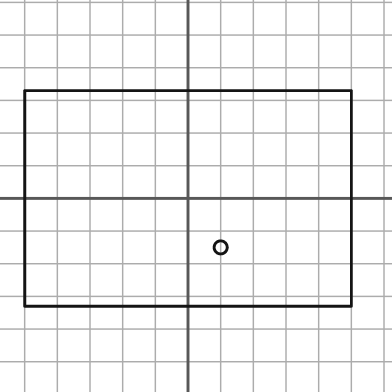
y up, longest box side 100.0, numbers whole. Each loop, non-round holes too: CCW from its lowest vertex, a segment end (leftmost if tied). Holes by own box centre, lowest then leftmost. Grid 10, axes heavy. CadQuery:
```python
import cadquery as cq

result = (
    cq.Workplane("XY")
    .moveTo(-50.0, -33.0)
    .lineTo(50.0, -33.0)
    .lineTo(50.0, 33.0)
    .lineTo(-50.0, 33.0)
    .close()
    .moveTo(10.0, -15.0)
    .circle(2.0)
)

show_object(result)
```